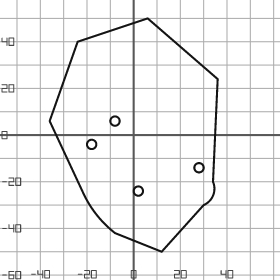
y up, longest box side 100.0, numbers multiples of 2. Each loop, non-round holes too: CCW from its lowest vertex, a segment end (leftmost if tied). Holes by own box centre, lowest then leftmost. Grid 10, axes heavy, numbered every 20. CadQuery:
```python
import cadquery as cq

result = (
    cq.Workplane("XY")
    .moveTo(12.0, -50.0)
    .lineTo(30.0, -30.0)
    .threePointArc((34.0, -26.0), (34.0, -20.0))
    .lineTo(36.0, 24.0)
    .lineTo(6.0, 50.0)
    .lineTo(-24.0, 40.0)
    .lineTo(-36.0, 6.0)
    .lineTo(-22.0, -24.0)
    .threePointArc((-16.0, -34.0), (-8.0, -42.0))
    .close()
    .moveTo(2.0, -24.0)
    .circle(2.0)
    .moveTo(28.0, -14.0)
    .circle(2.0)
    .moveTo(-18.0, -4.0)
    .circle(2.0)
    .moveTo(-8.0, 6.0)
    .circle(2.0)
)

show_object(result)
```